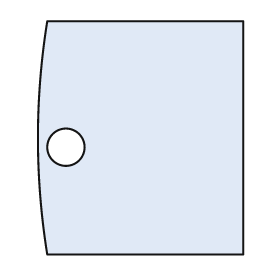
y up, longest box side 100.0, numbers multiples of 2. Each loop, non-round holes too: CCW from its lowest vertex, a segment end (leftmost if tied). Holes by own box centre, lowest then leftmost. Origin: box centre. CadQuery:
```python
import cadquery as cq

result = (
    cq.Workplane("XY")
    .moveTo(-40.0, -50.0)
    .lineTo(44.0, -50.0)
    .lineTo(44.0, 50.0)
    .lineTo(-40.0, 50.0)
    .threePointArc((-44.0, 0.0), (-40.0, -50.0))
    .close()
    .moveTo(-32.0, -4.0)
    .circle(8.0)
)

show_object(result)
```